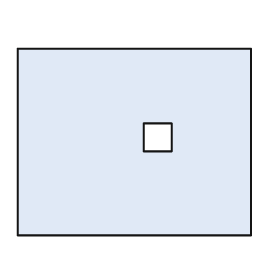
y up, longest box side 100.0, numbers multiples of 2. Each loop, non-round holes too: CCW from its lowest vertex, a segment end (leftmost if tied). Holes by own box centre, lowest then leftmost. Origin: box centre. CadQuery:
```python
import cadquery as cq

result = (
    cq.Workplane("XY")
    .moveTo(-50.0, -40.0)
    .lineTo(50.0, -40.0)
    .lineTo(50.0, 40.0)
    .lineTo(-50.0, 40.0)
    .close()
    .moveTo(4.0, -4.0)
    .lineTo(16.0, -4.0)
    .lineTo(16.0, 8.0)
    .lineTo(4.0, 8.0)
    .close()
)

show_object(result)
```